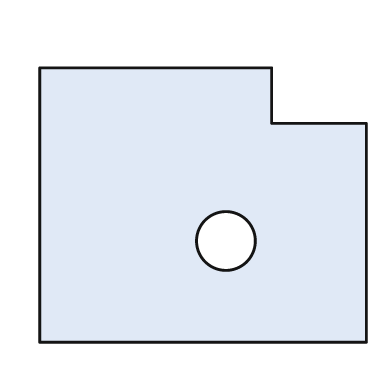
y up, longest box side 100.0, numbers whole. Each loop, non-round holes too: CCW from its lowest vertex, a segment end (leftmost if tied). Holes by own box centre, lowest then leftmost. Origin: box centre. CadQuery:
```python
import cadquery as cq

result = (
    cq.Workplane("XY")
    .moveTo(-50.0, -42.0)
    .lineTo(50.0, -42.0)
    .lineTo(50.0, 25.0)
    .lineTo(21.0, 25.0)
    .lineTo(21.0, 42.0)
    .lineTo(-50.0, 42.0)
    .close()
    .moveTo(7.0, -11.0)
    .circle(9.0)
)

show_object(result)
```